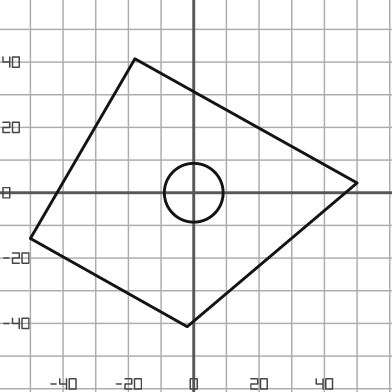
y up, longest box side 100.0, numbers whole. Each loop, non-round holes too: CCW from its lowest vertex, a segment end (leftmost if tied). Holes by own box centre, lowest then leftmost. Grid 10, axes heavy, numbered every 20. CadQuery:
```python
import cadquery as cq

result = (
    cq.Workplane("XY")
    .moveTo(-2.0, -41.0)
    .lineTo(50.0, 3.0)
    .lineTo(-18.0, 41.0)
    .lineTo(-50.0, -14.0)
    .close()
    .moveTo(0.0, 0.0)
    .circle(9.0)
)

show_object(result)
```